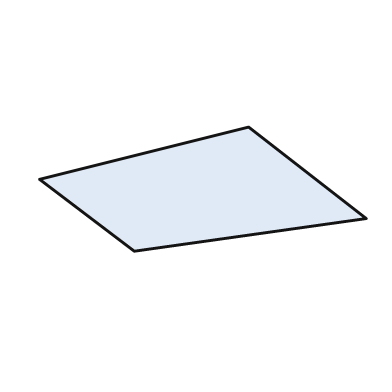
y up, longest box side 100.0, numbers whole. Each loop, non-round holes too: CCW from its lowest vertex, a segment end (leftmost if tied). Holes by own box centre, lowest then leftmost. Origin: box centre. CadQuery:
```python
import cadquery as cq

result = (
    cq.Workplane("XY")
    .moveTo(-21.0, -19.0)
    .lineTo(50.0, -9.0)
    .lineTo(14.0, 19.0)
    .lineTo(-50.0, 3.0)
    .close()
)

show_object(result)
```